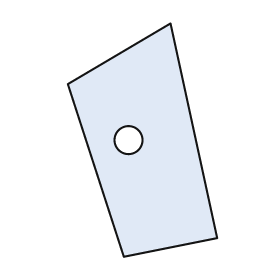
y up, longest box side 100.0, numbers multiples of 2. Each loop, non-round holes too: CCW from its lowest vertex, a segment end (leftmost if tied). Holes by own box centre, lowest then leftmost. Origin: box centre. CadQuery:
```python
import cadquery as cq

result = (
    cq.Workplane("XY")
    .moveTo(-8.0, -50.0)
    .lineTo(32.0, -42.0)
    .lineTo(12.0, 50.0)
    .lineTo(-32.0, 24.0)
    .close()
    .moveTo(-6.0, 0.0)
    .circle(6.0)
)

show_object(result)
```